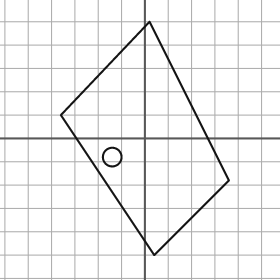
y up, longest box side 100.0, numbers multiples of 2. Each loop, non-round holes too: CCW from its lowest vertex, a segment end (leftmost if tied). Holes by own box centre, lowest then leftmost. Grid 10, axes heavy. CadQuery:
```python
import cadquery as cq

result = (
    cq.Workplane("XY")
    .moveTo(4.0, -50.0)
    .lineTo(36.0, -18.0)
    .lineTo(2.0, 50.0)
    .lineTo(-36.0, 10.0)
    .close()
    .moveTo(-14.0, -8.0)
    .circle(4.0)
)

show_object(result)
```